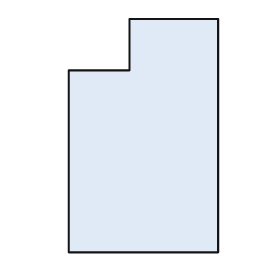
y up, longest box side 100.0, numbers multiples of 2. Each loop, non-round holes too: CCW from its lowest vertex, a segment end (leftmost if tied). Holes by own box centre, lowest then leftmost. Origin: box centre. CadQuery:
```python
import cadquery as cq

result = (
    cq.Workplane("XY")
    .moveTo(-32.0, -50.0)
    .lineTo(32.0, -50.0)
    .lineTo(32.0, 50.0)
    .lineTo(-6.0, 50.0)
    .lineTo(-6.0, 28.0)
    .lineTo(-32.0, 28.0)
    .close()
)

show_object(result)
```